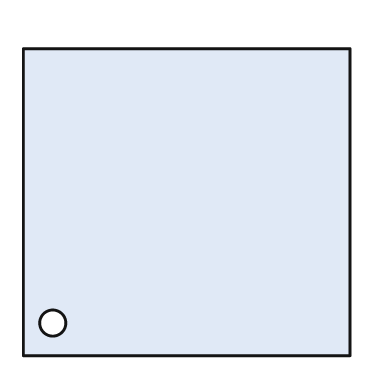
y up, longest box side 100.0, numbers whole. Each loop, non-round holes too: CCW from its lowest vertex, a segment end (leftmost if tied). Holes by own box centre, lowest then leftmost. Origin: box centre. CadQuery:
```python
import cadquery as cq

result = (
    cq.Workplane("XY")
    .moveTo(-50.0, -47.0)
    .lineTo(50.0, -47.0)
    .lineTo(50.0, 47.0)
    .lineTo(-50.0, 47.0)
    .close()
    .moveTo(-41.0, -37.0)
    .circle(4.0)
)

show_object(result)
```